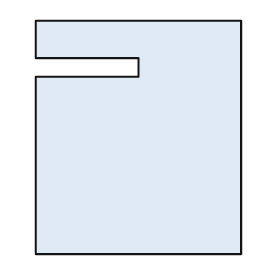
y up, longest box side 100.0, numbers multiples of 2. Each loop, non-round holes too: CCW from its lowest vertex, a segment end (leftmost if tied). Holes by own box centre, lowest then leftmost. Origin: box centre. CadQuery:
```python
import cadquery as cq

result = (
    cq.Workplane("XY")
    .moveTo(-44.0, -50.0)
    .lineTo(44.0, -50.0)
    .lineTo(44.0, 50.0)
    .lineTo(-44.0, 50.0)
    .lineTo(-44.0, 34.0)
    .lineTo(0.0, 34.0)
    .lineTo(0.0, 26.0)
    .lineTo(-44.0, 26.0)
    .close()
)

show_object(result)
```